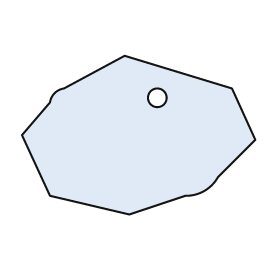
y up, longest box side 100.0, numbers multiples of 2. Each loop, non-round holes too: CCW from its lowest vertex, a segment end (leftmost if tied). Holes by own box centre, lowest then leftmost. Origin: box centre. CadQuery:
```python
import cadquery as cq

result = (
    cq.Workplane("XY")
    .moveTo(-4.0, -34.0)
    .lineTo(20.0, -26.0)
    .threePointArc((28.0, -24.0), (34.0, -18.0))
    .lineTo(50.0, -2.0)
    .lineTo(40.0, 20.0)
    .lineTo(-6.0, 34.0)
    .lineTo(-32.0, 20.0)
    .threePointArc((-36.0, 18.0), (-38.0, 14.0))
    .lineTo(-50.0, 0.0)
    .lineTo(-38.0, -26.0)
    .close()
    .moveTo(8.0, 16.0)
    .circle(4.0)
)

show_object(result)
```